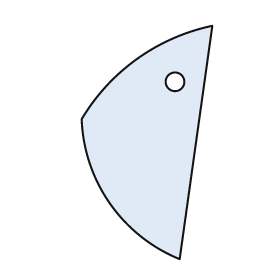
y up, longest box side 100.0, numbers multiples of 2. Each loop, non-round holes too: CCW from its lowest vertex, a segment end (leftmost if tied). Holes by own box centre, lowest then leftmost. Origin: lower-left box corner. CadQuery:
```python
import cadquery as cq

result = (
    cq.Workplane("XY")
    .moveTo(42.0, 0.0)
    .lineTo(56.0, 100.0)
    .threePointArc((24.0, 86.0), (0.0, 60.0))
    .threePointArc((12.0, 24.0), (42.0, 0.0))
    .close()
    .moveTo(40.0, 76.0)
    .circle(4.0)
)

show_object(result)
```